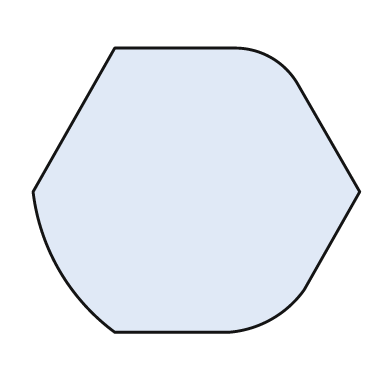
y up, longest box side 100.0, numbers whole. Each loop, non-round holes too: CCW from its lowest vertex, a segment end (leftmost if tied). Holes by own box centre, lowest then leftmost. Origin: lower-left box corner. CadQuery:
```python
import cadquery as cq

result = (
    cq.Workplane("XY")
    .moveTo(25.0, 0.0)
    .lineTo(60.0, 0.0)
    .threePointArc((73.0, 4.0), (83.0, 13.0))
    .lineTo(100.0, 43.0)
    .lineTo(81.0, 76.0)
    .threePointArc((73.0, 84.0), (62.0, 87.0))
    .lineTo(25.0, 87.0)
    .lineTo(0.0, 43.0)
    .threePointArc((8.0, 19.0), (25.0, 0.0))
    .close()
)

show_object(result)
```